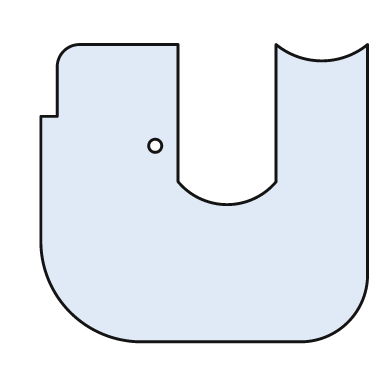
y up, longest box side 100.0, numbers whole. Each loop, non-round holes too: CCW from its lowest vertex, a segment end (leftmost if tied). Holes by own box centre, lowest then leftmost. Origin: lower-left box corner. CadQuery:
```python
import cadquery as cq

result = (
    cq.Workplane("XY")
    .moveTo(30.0, 0.0)
    .lineTo(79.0, 0.0)
    .threePointArc((94.0, 6.0), (100.0, 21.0))
    .lineTo(100.0, 91.0)
    .threePointArc((86.0, 86.0), (72.0, 91.0))
    .lineTo(72.0, 49.0)
    .threePointArc((57.0, 42.0), (42.0, 49.0))
    .lineTo(42.0, 91.0)
    .lineTo(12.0, 91.0)
    .threePointArc((7.0, 89.0), (5.0, 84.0))
    .lineTo(5.0, 69.0)
    .lineTo(0.0, 69.0)
    .lineTo(0.0, 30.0)
    .threePointArc((9.0, 9.0), (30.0, 0.0))
    .close()
    .moveTo(35.0, 60.0)
    .circle(2.0)
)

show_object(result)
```